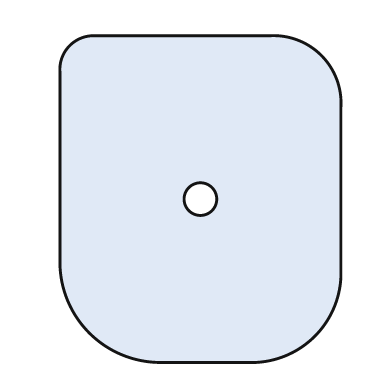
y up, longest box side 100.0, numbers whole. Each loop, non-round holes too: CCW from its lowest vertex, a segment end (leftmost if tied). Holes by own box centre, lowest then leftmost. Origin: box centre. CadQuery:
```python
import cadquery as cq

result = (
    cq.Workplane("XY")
    .moveTo(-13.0, -50.0)
    .lineTo(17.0, -50.0)
    .threePointArc((35.0, -42.0), (43.0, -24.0))
    .lineTo(43.0, 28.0)
    .threePointArc((37.0, 44.0), (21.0, 50.0))
    .lineTo(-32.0, 50.0)
    .threePointArc((-40.0, 47.0), (-43.0, 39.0))
    .lineTo(-43.0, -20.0)
    .threePointArc((-34.0, -41.0), (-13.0, -50.0))
    .close()
    .moveTo(0.0, 0.0)
    .circle(5.0)
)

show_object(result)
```